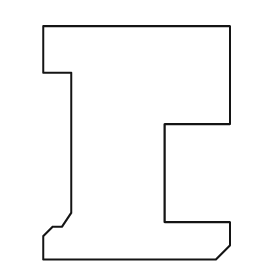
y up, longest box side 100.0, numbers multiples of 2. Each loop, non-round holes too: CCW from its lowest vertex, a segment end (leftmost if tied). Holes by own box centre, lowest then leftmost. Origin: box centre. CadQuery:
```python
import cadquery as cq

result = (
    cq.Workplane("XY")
    .moveTo(-40.0, -50.0)
    .lineTo(34.0, -50.0)
    .lineTo(40.0, -44.0)
    .lineTo(40.0, -34.0)
    .lineTo(12.0, -34.0)
    .lineTo(12.0, 8.0)
    .lineTo(40.0, 8.0)
    .lineTo(40.0, 50.0)
    .lineTo(-40.0, 50.0)
    .lineTo(-40.0, 30.0)
    .lineTo(-28.0, 30.0)
    .lineTo(-28.0, -30.0)
    .lineTo(-32.0, -36.0)
    .lineTo(-36.0, -36.0)
    .lineTo(-40.0, -40.0)
    .close()
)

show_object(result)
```